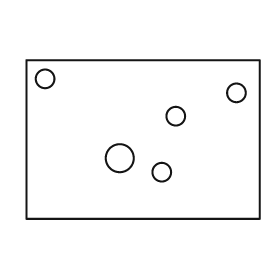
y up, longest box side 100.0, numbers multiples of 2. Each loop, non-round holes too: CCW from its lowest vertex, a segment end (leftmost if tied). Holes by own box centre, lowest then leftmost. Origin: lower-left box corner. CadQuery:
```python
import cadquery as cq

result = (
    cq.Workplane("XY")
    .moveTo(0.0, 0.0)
    .lineTo(100.0, 0.0)
    .lineTo(100.0, 68.0)
    .lineTo(0.0, 68.0)
    .close()
    .moveTo(58.0, 20.0)
    .circle(4.0)
    .moveTo(40.0, 26.0)
    .circle(6.0)
    .moveTo(64.0, 44.0)
    .circle(4.0)
    .moveTo(90.0, 54.0)
    .circle(4.0)
    .moveTo(8.0, 60.0)
    .circle(4.0)
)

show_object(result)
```